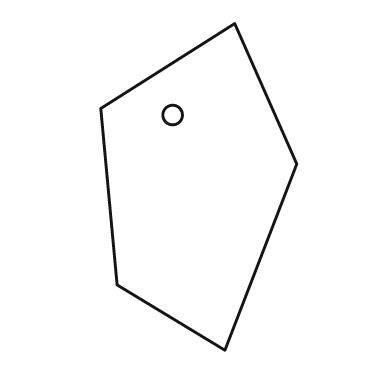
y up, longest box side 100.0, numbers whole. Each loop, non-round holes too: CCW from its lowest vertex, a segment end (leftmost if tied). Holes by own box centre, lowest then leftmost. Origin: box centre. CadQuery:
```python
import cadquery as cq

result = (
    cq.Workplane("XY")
    .moveTo(8.0, -50.0)
    .lineTo(30.0, 7.0)
    .lineTo(11.0, 50.0)
    .lineTo(-30.0, 24.0)
    .lineTo(-25.0, -30.0)
    .close()
    .moveTo(-8.0, 22.0)
    .circle(3.0)
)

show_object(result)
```